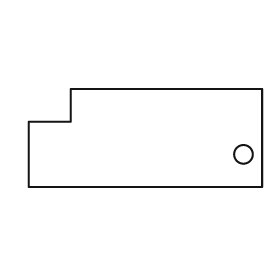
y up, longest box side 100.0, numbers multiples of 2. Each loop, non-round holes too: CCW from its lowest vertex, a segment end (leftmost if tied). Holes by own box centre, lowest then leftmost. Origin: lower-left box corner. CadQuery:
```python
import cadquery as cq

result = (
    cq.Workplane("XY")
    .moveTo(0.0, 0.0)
    .lineTo(100.0, 0.0)
    .lineTo(100.0, 42.0)
    .lineTo(18.0, 42.0)
    .lineTo(18.0, 28.0)
    .lineTo(0.0, 28.0)
    .close()
    .moveTo(92.0, 14.0)
    .circle(4.0)
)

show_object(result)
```